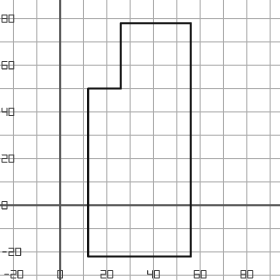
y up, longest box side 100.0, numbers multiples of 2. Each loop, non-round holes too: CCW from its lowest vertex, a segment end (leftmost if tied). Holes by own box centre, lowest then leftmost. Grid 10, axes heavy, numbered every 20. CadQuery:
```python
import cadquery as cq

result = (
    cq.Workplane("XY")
    .moveTo(12.0, -22.0)
    .lineTo(56.0, -22.0)
    .lineTo(56.0, 78.0)
    .lineTo(26.0, 78.0)
    .lineTo(26.0, 50.0)
    .lineTo(12.0, 50.0)
    .close()
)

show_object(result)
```